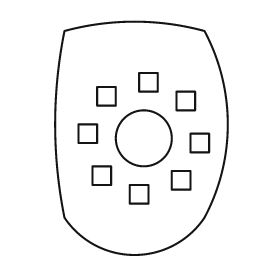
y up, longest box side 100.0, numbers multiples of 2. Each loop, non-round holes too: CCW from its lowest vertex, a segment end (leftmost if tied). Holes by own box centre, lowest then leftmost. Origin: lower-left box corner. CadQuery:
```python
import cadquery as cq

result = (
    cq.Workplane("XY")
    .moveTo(4.0, 16.0)
    .threePointArc((34.0, 0.0), (64.0, 16.0))
    .threePointArc((74.0, 56.0), (64.0, 96.0))
    .threePointArc((34.0, 100.0), (4.0, 96.0))
    .threePointArc((0.0, 56.0), (4.0, 16.0))
    .close()
    .moveTo(32.0, 22.0)
    .lineTo(40.0, 22.0)
    .lineTo(40.0, 30.0)
    .lineTo(32.0, 30.0)
    .close()
    .moveTo(50.0, 28.0)
    .lineTo(58.0, 28.0)
    .lineTo(58.0, 36.0)
    .lineTo(50.0, 36.0)
    .close()
    .moveTo(16.0, 30.0)
    .lineTo(24.0, 30.0)
    .lineTo(24.0, 38.0)
    .lineTo(16.0, 38.0)
    .close()
    .moveTo(58.0, 44.0)
    .lineTo(66.0, 44.0)
    .lineTo(66.0, 52.0)
    .lineTo(58.0, 52.0)
    .close()
    .moveTo(38.0, 50.0)
    .circle(12.0)
    .moveTo(10.0, 48.0)
    .lineTo(18.0, 48.0)
    .lineTo(18.0, 56.0)
    .lineTo(10.0, 56.0)
    .close()
    .moveTo(52.0, 62.0)
    .lineTo(60.0, 62.0)
    .lineTo(60.0, 70.0)
    .lineTo(52.0, 70.0)
    .close()
    .moveTo(18.0, 64.0)
    .lineTo(26.0, 64.0)
    .lineTo(26.0, 72.0)
    .lineTo(18.0, 72.0)
    .close()
    .moveTo(36.0, 70.0)
    .lineTo(44.0, 70.0)
    .lineTo(44.0, 78.0)
    .lineTo(36.0, 78.0)
    .close()
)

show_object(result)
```